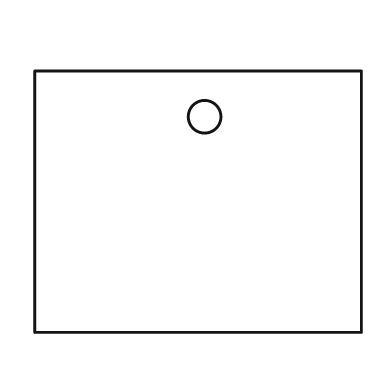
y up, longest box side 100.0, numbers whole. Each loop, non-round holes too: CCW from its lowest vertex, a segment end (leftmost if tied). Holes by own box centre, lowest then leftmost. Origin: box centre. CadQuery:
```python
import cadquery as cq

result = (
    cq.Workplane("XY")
    .moveTo(-50.0, -40.0)
    .lineTo(50.0, -40.0)
    .lineTo(50.0, 40.0)
    .lineTo(-50.0, 40.0)
    .close()
    .moveTo(2.0, 26.0)
    .circle(5.0)
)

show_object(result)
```